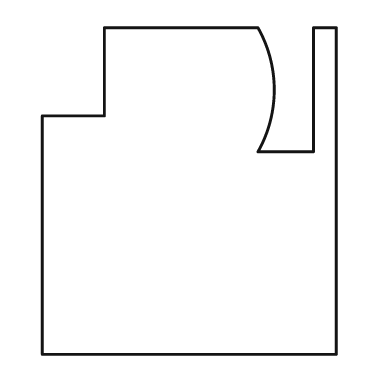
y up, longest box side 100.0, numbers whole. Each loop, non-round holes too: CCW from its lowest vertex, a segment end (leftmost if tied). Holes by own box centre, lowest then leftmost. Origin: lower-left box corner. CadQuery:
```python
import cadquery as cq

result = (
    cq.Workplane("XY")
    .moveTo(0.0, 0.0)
    .lineTo(90.0, 0.0)
    .lineTo(90.0, 100.0)
    .lineTo(83.0, 100.0)
    .lineTo(83.0, 62.0)
    .lineTo(66.0, 62.0)
    .threePointArc((71.0, 81.0), (66.0, 100.0))
    .lineTo(19.0, 100.0)
    .lineTo(19.0, 73.0)
    .lineTo(0.0, 73.0)
    .close()
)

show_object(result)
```